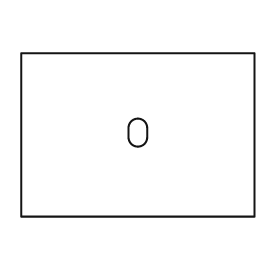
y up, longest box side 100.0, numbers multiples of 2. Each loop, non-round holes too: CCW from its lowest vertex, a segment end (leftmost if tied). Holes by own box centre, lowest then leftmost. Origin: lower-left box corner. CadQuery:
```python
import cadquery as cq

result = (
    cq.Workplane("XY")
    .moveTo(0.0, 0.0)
    .lineTo(100.0, 0.0)
    .lineTo(100.0, 70.0)
    .lineTo(0.0, 70.0)
    .close()
    .moveTo(46.0, 34.0)
    .threePointArc((50.0, 30.0), (54.0, 34.0))
    .lineTo(54.0, 38.0)
    .threePointArc((50.0, 42.0), (46.0, 38.0))
    .close()
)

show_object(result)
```